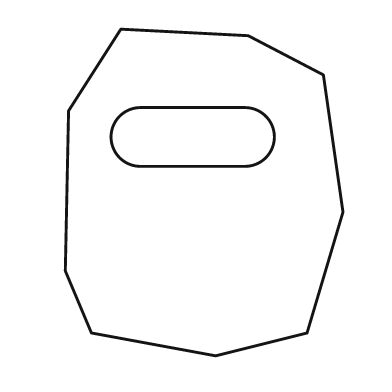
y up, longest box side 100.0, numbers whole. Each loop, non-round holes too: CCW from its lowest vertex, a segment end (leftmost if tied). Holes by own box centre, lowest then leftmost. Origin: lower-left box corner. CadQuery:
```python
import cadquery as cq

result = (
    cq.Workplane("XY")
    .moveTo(46.0, 0.0)
    .lineTo(74.0, 7.0)
    .lineTo(85.0, 44.0)
    .lineTo(79.0, 86.0)
    .lineTo(56.0, 98.0)
    .lineTo(17.0, 100.0)
    .lineTo(1.0, 75.0)
    .lineTo(0.0, 26.0)
    .lineTo(8.0, 7.0)
    .close()
    .moveTo(23.0, 58.0)
    .lineTo(55.0, 58.0)
    .threePointArc((64.0, 67.0), (55.0, 76.0))
    .lineTo(23.0, 76.0)
    .threePointArc((14.0, 67.0), (23.0, 58.0))
    .close()
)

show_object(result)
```